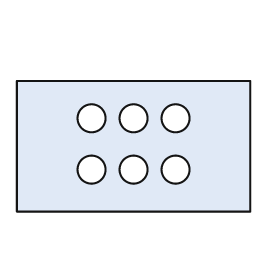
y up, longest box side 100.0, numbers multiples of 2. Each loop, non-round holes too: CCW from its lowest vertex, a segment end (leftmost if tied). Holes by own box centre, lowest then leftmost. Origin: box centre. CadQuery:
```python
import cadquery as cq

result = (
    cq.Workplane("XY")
    .moveTo(-50.0, -28.0)
    .lineTo(50.0, -28.0)
    .lineTo(50.0, 28.0)
    .lineTo(-50.0, 28.0)
    .close()
    .moveTo(-18.0, -10.0)
    .circle(6.0)
    .moveTo(0.0, -10.0)
    .circle(6.0)
    .moveTo(18.0, -10.0)
    .circle(6.0)
    .moveTo(-18.0, 12.0)
    .circle(6.0)
    .moveTo(0.0, 12.0)
    .circle(6.0)
    .moveTo(18.0, 12.0)
    .circle(6.0)
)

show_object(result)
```